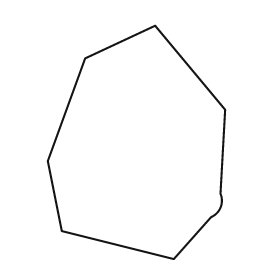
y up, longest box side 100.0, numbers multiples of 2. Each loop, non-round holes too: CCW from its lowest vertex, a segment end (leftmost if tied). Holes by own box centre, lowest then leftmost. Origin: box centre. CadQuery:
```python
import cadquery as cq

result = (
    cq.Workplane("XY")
    .moveTo(16.0, -50.0)
    .lineTo(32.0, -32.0)
    .threePointArc((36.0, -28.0), (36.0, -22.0))
    .lineTo(38.0, 14.0)
    .lineTo(8.0, 50.0)
    .lineTo(-22.0, 36.0)
    .lineTo(-38.0, -8.0)
    .lineTo(-32.0, -38.0)
    .close()
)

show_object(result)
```